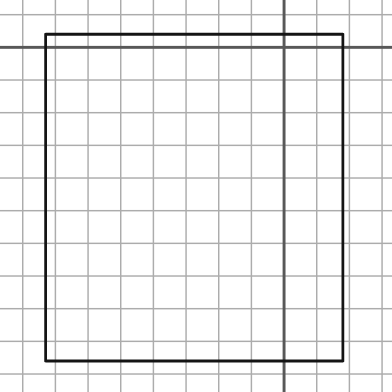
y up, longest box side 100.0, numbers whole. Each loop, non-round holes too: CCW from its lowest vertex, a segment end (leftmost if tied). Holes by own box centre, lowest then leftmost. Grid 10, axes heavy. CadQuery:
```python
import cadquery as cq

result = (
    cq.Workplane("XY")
    .moveTo(-73.0, -96.0)
    .lineTo(18.0, -96.0)
    .lineTo(18.0, 4.0)
    .lineTo(-73.0, 4.0)
    .close()
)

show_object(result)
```